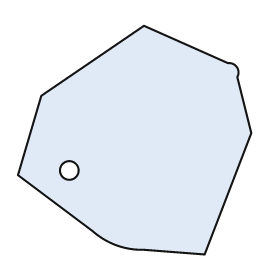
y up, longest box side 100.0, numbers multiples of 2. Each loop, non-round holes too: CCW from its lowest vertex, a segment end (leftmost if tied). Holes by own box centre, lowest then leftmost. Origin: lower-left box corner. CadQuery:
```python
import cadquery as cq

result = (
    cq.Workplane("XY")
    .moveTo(80.0, 0.0)
    .lineTo(100.0, 52.0)
    .lineTo(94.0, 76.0)
    .threePointArc((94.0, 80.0), (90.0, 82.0))
    .lineTo(54.0, 98.0)
    .lineTo(10.0, 68.0)
    .lineTo(0.0, 34.0)
    .lineTo(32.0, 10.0)
    .threePointArc((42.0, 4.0), (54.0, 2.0))
    .close()
    .moveTo(22.0, 36.0)
    .circle(4.0)
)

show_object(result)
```